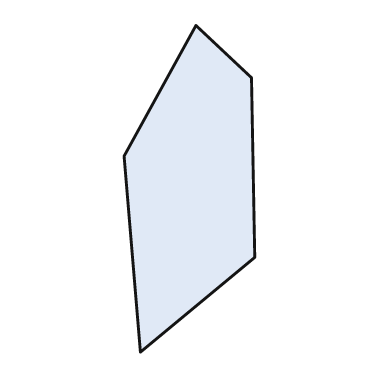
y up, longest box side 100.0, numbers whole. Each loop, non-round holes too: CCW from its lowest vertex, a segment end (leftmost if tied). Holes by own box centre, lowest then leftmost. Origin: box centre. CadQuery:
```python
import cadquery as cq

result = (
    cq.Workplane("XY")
    .moveTo(-15.0, -50.0)
    .lineTo(20.0, -21.0)
    .lineTo(19.0, 34.0)
    .lineTo(2.0, 50.0)
    .lineTo(-20.0, 10.0)
    .close()
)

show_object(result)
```